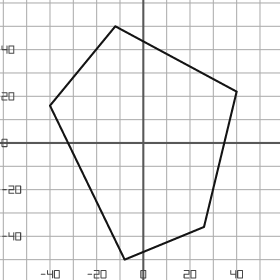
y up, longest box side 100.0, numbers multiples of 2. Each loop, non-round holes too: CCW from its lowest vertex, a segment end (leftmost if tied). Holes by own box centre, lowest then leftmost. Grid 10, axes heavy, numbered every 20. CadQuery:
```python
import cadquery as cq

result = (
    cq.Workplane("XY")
    .moveTo(-8.0, -50.0)
    .lineTo(26.0, -36.0)
    .lineTo(40.0, 22.0)
    .lineTo(-12.0, 50.0)
    .lineTo(-40.0, 16.0)
    .close()
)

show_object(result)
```